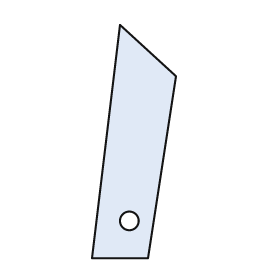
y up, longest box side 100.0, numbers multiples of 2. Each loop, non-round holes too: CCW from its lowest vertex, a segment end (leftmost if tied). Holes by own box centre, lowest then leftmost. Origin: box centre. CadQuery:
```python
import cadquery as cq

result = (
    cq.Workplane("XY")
    .moveTo(-18.0, -50.0)
    .lineTo(6.0, -50.0)
    .lineTo(18.0, 28.0)
    .lineTo(-6.0, 50.0)
    .close()
    .moveTo(-2.0, -34.0)
    .circle(4.0)
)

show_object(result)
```